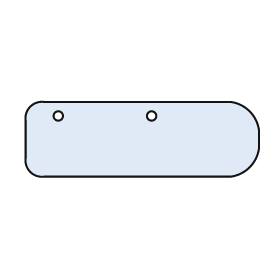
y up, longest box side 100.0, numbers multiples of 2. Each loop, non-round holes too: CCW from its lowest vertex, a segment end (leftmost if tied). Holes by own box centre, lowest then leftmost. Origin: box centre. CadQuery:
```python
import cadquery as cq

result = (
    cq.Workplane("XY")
    .moveTo(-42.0, -16.0)
    .lineTo(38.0, -16.0)
    .threePointArc((46.0, -12.0), (50.0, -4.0))
    .lineTo(50.0, 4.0)
    .threePointArc((46.0, 12.0), (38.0, 16.0))
    .lineTo(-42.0, 16.0)
    .threePointArc((-48.0, 14.0), (-50.0, 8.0))
    .lineTo(-50.0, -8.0)
    .threePointArc((-48.0, -14.0), (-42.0, -16.0))
    .close()
    .moveTo(-36.0, 10.0)
    .circle(2.0)
    .moveTo(4.0, 10.0)
    .circle(2.0)
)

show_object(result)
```